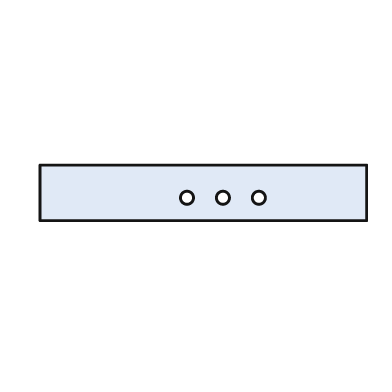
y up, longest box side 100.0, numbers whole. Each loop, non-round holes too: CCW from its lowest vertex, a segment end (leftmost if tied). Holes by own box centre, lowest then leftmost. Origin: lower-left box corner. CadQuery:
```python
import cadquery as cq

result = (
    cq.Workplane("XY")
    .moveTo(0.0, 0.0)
    .lineTo(100.0, 0.0)
    .lineTo(100.0, 17.0)
    .lineTo(0.0, 17.0)
    .close()
    .moveTo(45.0, 7.0)
    .circle(2.0)
    .moveTo(56.0, 7.0)
    .circle(2.0)
    .moveTo(67.0, 7.0)
    .circle(2.0)
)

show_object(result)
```